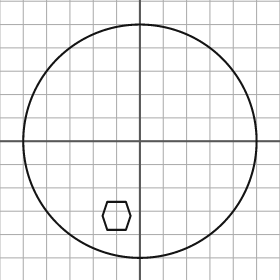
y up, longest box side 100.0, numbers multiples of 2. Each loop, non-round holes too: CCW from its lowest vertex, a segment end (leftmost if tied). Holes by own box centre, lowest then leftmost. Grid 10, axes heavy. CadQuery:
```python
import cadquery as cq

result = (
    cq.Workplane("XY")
    .moveTo(0.0, 0.0)
    .circle(50.0)
    .moveTo(-14.0, -38.0)
    .lineTo(-6.0, -38.0)
    .lineTo(-4.0, -32.0)
    .lineTo(-6.0, -26.0)
    .lineTo(-14.0, -26.0)
    .lineTo(-16.0, -32.0)
    .close()
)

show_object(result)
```